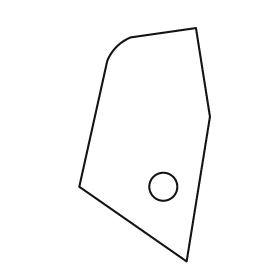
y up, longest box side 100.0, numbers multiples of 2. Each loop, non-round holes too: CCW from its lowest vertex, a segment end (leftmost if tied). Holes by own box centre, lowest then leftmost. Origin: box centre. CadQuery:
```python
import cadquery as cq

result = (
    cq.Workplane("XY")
    .moveTo(18.0, -50.0)
    .lineTo(28.0, 12.0)
    .lineTo(22.0, 50.0)
    .lineTo(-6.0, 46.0)
    .threePointArc((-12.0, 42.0), (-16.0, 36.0))
    .lineTo(-28.0, -18.0)
    .close()
    .moveTo(8.0, -18.0)
    .circle(6.0)
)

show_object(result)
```